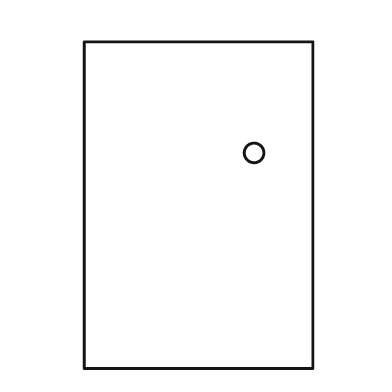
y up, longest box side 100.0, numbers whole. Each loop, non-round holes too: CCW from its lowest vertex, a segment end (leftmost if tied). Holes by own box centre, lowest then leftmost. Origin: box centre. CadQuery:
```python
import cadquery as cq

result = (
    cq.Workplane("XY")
    .moveTo(-35.0, -50.0)
    .lineTo(35.0, -50.0)
    .lineTo(35.0, 50.0)
    .lineTo(-35.0, 50.0)
    .close()
    .moveTo(17.0, 16.0)
    .circle(3.0)
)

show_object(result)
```